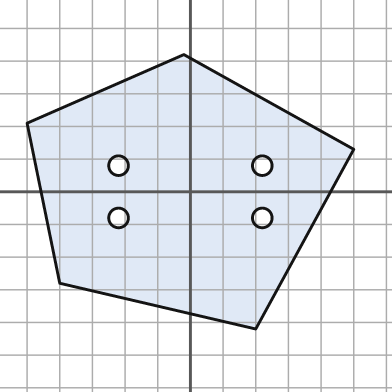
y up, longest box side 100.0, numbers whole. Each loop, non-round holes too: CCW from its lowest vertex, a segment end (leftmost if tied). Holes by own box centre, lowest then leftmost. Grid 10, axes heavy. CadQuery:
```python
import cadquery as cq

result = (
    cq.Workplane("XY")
    .moveTo(20.0, -42.0)
    .lineTo(50.0, 13.0)
    .lineTo(-2.0, 42.0)
    .lineTo(-50.0, 21.0)
    .lineTo(-40.0, -28.0)
    .close()
    .moveTo(-22.0, -8.0)
    .circle(3.0)
    .moveTo(22.0, -8.0)
    .circle(3.0)
    .moveTo(-22.0, 8.0)
    .circle(3.0)
    .moveTo(22.0, 8.0)
    .circle(3.0)
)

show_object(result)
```